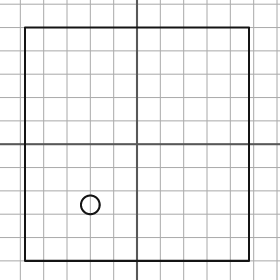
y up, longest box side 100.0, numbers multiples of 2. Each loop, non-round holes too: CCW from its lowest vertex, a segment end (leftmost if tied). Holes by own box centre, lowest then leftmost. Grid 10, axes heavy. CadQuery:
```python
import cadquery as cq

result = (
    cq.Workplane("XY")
    .moveTo(-48.0, -50.0)
    .lineTo(48.0, -50.0)
    .lineTo(48.0, 50.0)
    .lineTo(-48.0, 50.0)
    .close()
    .moveTo(-20.0, -26.0)
    .circle(4.0)
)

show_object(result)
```